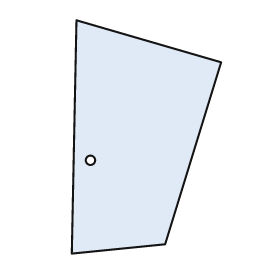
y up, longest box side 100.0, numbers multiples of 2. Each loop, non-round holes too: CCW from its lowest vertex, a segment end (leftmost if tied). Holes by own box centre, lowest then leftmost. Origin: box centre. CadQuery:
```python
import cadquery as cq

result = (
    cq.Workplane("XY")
    .moveTo(-32.0, -50.0)
    .lineTo(8.0, -46.0)
    .lineTo(32.0, 32.0)
    .lineTo(-30.0, 50.0)
    .close()
    .moveTo(-24.0, -10.0)
    .circle(2.0)
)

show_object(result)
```